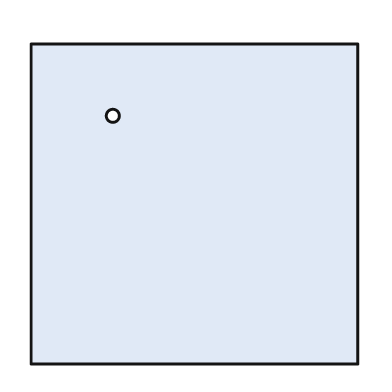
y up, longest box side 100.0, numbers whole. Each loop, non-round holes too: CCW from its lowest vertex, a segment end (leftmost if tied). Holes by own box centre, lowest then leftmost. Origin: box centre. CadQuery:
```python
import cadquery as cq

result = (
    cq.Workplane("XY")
    .moveTo(-50.0, -49.0)
    .lineTo(50.0, -49.0)
    .lineTo(50.0, 49.0)
    .lineTo(-50.0, 49.0)
    .close()
    .moveTo(-25.0, 27.0)
    .circle(2.0)
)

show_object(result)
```